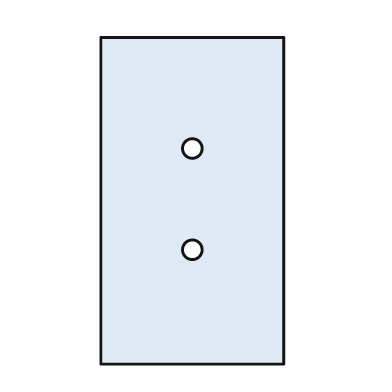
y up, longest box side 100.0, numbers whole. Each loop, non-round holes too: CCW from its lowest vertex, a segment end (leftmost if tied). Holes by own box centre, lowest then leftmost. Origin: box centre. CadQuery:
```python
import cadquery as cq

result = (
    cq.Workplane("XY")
    .moveTo(-28.0, -50.0)
    .lineTo(28.0, -50.0)
    .lineTo(28.0, 50.0)
    .lineTo(-28.0, 50.0)
    .close()
    .moveTo(0.0, -15.0)
    .circle(3.0)
    .moveTo(0.0, 16.0)
    .circle(3.0)
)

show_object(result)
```